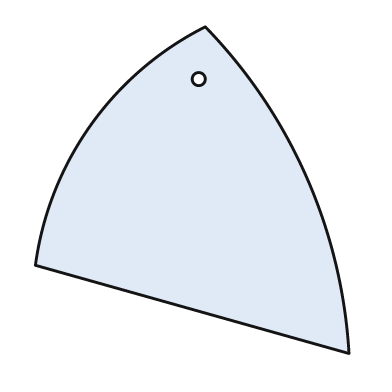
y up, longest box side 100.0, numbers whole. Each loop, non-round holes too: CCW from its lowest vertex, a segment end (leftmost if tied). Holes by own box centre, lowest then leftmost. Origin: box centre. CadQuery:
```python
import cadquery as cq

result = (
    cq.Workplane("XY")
    .moveTo(48.0, -50.0)
    .threePointArc((35.0, 4.0), (4.0, 50.0))
    .threePointArc((-31.0, 20.0), (-48.0, -23.0))
    .close()
    .moveTo(2.0, 34.0)
    .circle(2.0)
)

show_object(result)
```